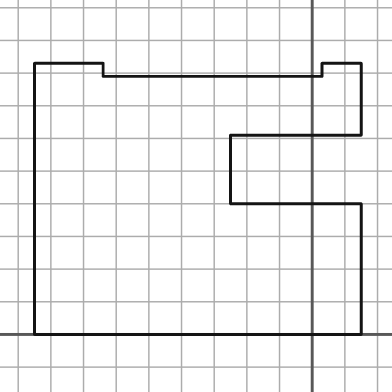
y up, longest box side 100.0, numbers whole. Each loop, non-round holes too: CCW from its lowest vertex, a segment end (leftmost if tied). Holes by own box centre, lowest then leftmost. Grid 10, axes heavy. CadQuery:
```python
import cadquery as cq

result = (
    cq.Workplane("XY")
    .moveTo(-85.0, 0.0)
    .lineTo(15.0, 0.0)
    .lineTo(15.0, 40.0)
    .lineTo(-25.0, 40.0)
    .lineTo(-25.0, 61.0)
    .lineTo(15.0, 61.0)
    .lineTo(15.0, 83.0)
    .lineTo(3.0, 83.0)
    .lineTo(3.0, 79.0)
    .lineTo(-64.0, 79.0)
    .lineTo(-64.0, 83.0)
    .lineTo(-85.0, 83.0)
    .close()
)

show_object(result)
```